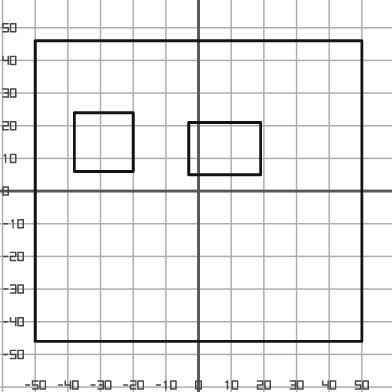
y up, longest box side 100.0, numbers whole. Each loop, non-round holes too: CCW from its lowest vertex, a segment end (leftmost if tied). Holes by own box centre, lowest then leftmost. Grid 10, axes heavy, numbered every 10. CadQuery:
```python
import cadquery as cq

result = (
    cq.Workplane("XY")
    .moveTo(-50.0, -46.0)
    .lineTo(50.0, -46.0)
    .lineTo(50.0, 46.0)
    .lineTo(-50.0, 46.0)
    .close()
    .moveTo(-3.0, 5.0)
    .lineTo(19.0, 5.0)
    .lineTo(19.0, 21.0)
    .lineTo(-3.0, 21.0)
    .close()
    .moveTo(-38.0, 6.0)
    .lineTo(-20.0, 6.0)
    .lineTo(-20.0, 24.0)
    .lineTo(-38.0, 24.0)
    .close()
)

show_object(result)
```